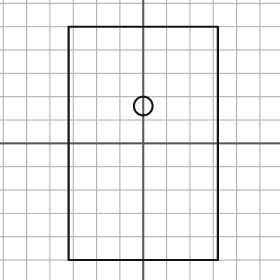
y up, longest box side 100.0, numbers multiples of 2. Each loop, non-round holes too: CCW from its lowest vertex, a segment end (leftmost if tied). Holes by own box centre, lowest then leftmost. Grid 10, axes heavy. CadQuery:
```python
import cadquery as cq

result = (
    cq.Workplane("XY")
    .moveTo(-32.0, -50.0)
    .lineTo(32.0, -50.0)
    .lineTo(32.0, 50.0)
    .lineTo(-32.0, 50.0)
    .close()
    .moveTo(0.0, 16.0)
    .circle(4.0)
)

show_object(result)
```